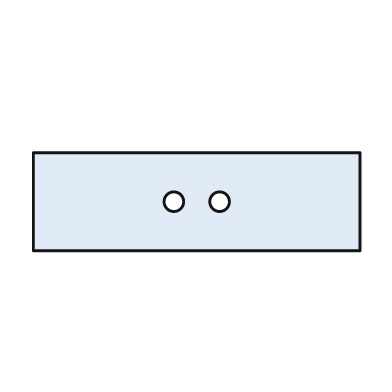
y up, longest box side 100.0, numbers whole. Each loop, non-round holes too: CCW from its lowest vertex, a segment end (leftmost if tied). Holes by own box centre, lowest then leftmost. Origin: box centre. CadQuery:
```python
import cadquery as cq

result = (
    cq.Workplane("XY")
    .moveTo(-50.0, -15.0)
    .lineTo(50.0, -15.0)
    .lineTo(50.0, 15.0)
    .lineTo(-50.0, 15.0)
    .close()
    .moveTo(-7.0, 0.0)
    .circle(3.0)
    .moveTo(7.0, 0.0)
    .circle(3.0)
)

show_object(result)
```